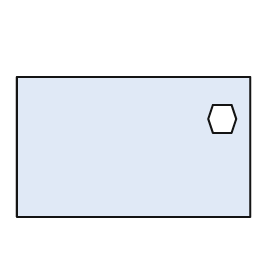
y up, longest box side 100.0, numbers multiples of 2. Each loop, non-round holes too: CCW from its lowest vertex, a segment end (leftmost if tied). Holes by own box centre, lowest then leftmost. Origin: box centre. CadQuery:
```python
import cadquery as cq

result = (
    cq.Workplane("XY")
    .moveTo(-50.0, -30.0)
    .lineTo(50.0, -30.0)
    .lineTo(50.0, 30.0)
    .lineTo(-50.0, 30.0)
    .close()
    .moveTo(34.0, 6.0)
    .lineTo(42.0, 6.0)
    .lineTo(44.0, 12.0)
    .lineTo(42.0, 18.0)
    .lineTo(34.0, 18.0)
    .lineTo(32.0, 12.0)
    .close()
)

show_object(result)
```